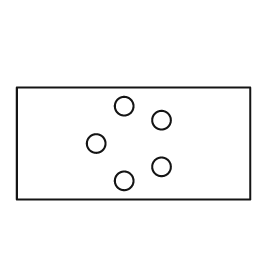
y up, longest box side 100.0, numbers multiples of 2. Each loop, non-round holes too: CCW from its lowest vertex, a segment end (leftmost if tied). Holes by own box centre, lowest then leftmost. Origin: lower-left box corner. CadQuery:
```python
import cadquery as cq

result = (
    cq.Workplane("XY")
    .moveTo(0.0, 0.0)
    .lineTo(100.0, 0.0)
    .lineTo(100.0, 48.0)
    .lineTo(0.0, 48.0)
    .close()
    .moveTo(46.0, 8.0)
    .circle(4.0)
    .moveTo(62.0, 14.0)
    .circle(4.0)
    .moveTo(34.0, 24.0)
    .circle(4.0)
    .moveTo(62.0, 34.0)
    .circle(4.0)
    .moveTo(46.0, 40.0)
    .circle(4.0)
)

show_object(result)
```